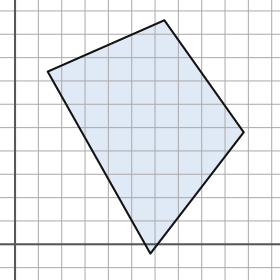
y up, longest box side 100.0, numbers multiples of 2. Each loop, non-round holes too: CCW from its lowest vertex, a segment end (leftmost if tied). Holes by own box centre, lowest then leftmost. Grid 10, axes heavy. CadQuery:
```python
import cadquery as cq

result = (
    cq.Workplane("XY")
    .moveTo(58.0, -4.0)
    .lineTo(98.0, 48.0)
    .lineTo(64.0, 96.0)
    .lineTo(14.0, 74.0)
    .close()
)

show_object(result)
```